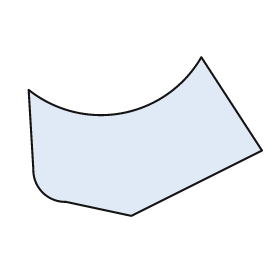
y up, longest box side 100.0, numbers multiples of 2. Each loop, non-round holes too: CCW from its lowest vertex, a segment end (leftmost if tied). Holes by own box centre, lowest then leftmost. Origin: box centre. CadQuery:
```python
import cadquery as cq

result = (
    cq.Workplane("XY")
    .moveTo(-6.0, -34.0)
    .lineTo(50.0, -6.0)
    .lineTo(24.0, 34.0)
    .threePointArc((-10.0, 10.0), (-50.0, 20.0))
    .lineTo(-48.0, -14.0)
    .threePointArc((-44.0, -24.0), (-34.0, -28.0))
    .close()
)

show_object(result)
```